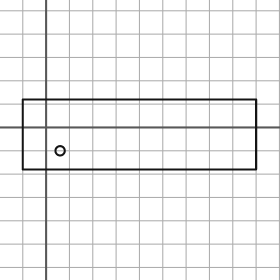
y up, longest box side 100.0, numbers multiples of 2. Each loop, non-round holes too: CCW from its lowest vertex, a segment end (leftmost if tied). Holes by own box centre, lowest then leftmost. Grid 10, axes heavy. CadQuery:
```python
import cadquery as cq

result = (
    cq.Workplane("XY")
    .moveTo(-10.0, -18.0)
    .lineTo(90.0, -18.0)
    .lineTo(90.0, 12.0)
    .lineTo(-10.0, 12.0)
    .close()
    .moveTo(6.0, -10.0)
    .circle(2.0)
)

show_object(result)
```